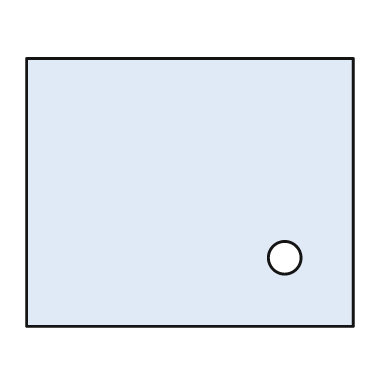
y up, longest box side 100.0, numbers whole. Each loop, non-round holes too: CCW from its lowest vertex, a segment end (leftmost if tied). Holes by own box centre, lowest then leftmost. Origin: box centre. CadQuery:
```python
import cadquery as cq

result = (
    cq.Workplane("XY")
    .moveTo(-50.0, -41.0)
    .lineTo(50.0, -41.0)
    .lineTo(50.0, 41.0)
    .lineTo(-50.0, 41.0)
    .close()
    .moveTo(29.0, -20.0)
    .circle(5.0)
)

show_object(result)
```